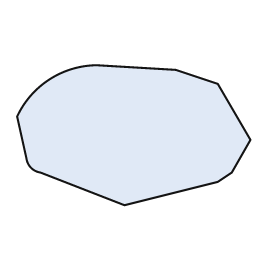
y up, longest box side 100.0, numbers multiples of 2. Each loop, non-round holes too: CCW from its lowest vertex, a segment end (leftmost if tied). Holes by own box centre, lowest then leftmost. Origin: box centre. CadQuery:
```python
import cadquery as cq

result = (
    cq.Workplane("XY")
    .moveTo(-4.0, -30.0)
    .lineTo(36.0, -20.0)
    .lineTo(42.0, -16.0)
    .lineTo(50.0, -2.0)
    .lineTo(36.0, 22.0)
    .lineTo(18.0, 28.0)
    .lineTo(-16.0, 30.0)
    .threePointArc((-36.0, 24.0), (-50.0, 8.0))
    .lineTo(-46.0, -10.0)
    .threePointArc((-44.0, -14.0), (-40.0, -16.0))
    .close()
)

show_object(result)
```